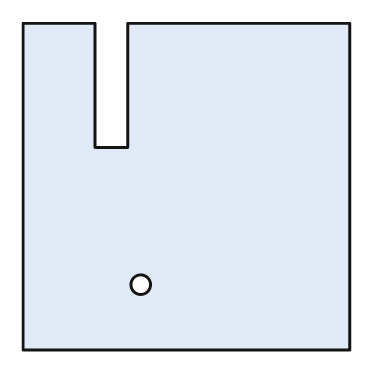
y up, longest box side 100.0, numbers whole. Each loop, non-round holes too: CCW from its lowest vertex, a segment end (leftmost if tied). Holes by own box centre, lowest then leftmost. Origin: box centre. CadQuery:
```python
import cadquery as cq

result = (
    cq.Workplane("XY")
    .moveTo(-50.0, -50.0)
    .lineTo(50.0, -50.0)
    .lineTo(50.0, 50.0)
    .lineTo(-18.0, 50.0)
    .lineTo(-18.0, 12.0)
    .lineTo(-28.0, 12.0)
    .lineTo(-28.0, 50.0)
    .lineTo(-50.0, 50.0)
    .close()
    .moveTo(-14.0, -30.0)
    .circle(3.0)
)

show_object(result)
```